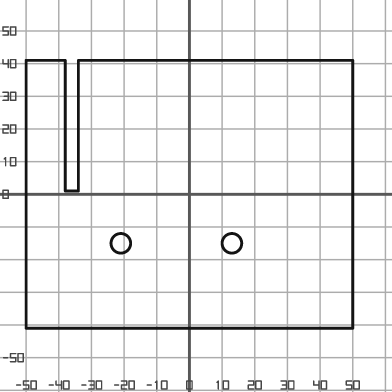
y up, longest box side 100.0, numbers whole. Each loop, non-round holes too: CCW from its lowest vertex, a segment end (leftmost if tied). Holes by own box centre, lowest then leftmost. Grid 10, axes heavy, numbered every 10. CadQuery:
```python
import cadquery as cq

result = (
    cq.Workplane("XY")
    .moveTo(-50.0, -41.0)
    .lineTo(50.0, -41.0)
    .lineTo(50.0, 41.0)
    .lineTo(-34.0, 41.0)
    .lineTo(-34.0, 1.0)
    .lineTo(-38.0, 1.0)
    .lineTo(-38.0, 41.0)
    .lineTo(-50.0, 41.0)
    .close()
    .moveTo(-21.0, -15.0)
    .circle(3.0)
    .moveTo(13.0, -15.0)
    .circle(3.0)
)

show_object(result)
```